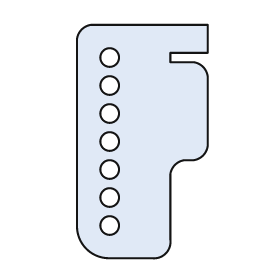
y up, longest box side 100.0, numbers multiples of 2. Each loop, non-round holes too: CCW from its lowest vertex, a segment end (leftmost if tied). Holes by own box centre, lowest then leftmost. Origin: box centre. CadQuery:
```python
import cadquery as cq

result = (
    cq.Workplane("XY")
    .moveTo(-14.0, -50.0)
    .lineTo(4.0, -50.0)
    .threePointArc((10.0, -48.0), (12.0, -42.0))
    .lineTo(12.0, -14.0)
    .threePointArc((14.0, -10.0), (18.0, -8.0))
    .lineTo(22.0, -8.0)
    .threePointArc((26.0, -6.0), (28.0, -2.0))
    .lineTo(28.0, 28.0)
    .threePointArc((26.0, 32.0), (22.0, 34.0))
    .lineTo(12.0, 34.0)
    .lineTo(12.0, 38.0)
    .lineTo(28.0, 38.0)
    .lineTo(28.0, 50.0)
    .lineTo(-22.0, 50.0)
    .threePointArc((-26.0, 48.0), (-28.0, 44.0))
    .lineTo(-28.0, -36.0)
    .threePointArc((-24.0, -46.0), (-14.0, -50.0))
    .close()
    .moveTo(-14.0, -36.0)
    .circle(4.0)
    .moveTo(-14.0, -24.0)
    .circle(4.0)
    .moveTo(-14.0, -12.0)
    .circle(4.0)
    .moveTo(-14.0, 0.0)
    .circle(4.0)
    .moveTo(-14.0, 12.0)
    .circle(4.0)
    .moveTo(-14.0, 24.0)
    .circle(4.0)
    .moveTo(-14.0, 36.0)
    .circle(4.0)
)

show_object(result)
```